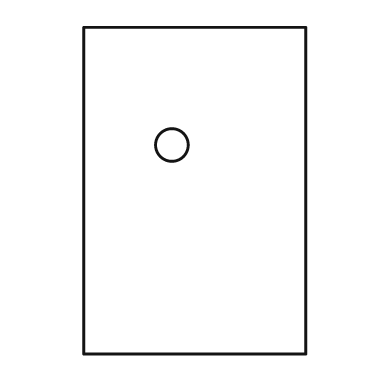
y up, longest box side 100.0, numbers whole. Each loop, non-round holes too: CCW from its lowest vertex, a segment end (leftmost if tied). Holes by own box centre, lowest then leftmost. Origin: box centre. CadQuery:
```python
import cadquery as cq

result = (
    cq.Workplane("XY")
    .moveTo(-34.0, -50.0)
    .lineTo(34.0, -50.0)
    .lineTo(34.0, 50.0)
    .lineTo(-34.0, 50.0)
    .close()
    .moveTo(-7.0, 14.0)
    .circle(5.0)
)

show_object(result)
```